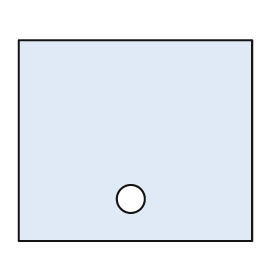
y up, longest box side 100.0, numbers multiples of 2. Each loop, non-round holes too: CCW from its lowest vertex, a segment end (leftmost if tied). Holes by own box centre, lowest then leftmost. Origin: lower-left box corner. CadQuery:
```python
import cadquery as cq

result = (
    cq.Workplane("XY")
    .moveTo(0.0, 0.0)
    .lineTo(100.0, 0.0)
    .lineTo(100.0, 86.0)
    .lineTo(0.0, 86.0)
    .close()
    .moveTo(48.0, 18.0)
    .circle(6.0)
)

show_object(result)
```